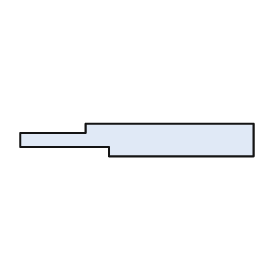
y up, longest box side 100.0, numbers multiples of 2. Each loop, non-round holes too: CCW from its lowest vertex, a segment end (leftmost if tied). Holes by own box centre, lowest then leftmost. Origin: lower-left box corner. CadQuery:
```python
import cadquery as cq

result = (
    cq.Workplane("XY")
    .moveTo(38.0, 0.0)
    .lineTo(100.0, 0.0)
    .lineTo(100.0, 14.0)
    .lineTo(28.0, 14.0)
    .lineTo(28.0, 10.0)
    .lineTo(0.0, 10.0)
    .lineTo(0.0, 4.0)
    .lineTo(38.0, 4.0)
    .close()
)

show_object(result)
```